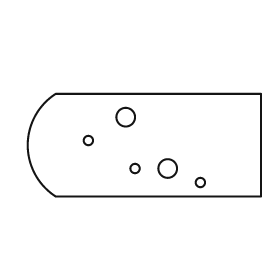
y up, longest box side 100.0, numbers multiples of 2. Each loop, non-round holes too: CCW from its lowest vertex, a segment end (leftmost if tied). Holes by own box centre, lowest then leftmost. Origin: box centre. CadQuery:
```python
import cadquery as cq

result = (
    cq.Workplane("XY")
    .moveTo(-38.0, -22.0)
    .lineTo(50.0, -22.0)
    .lineTo(50.0, 22.0)
    .lineTo(-38.0, 22.0)
    .threePointArc((-50.0, 0.0), (-38.0, -22.0))
    .close()
    .moveTo(24.0, -16.0)
    .circle(2.0)
    .moveTo(-4.0, -10.0)
    .circle(2.0)
    .moveTo(10.0, -10.0)
    .circle(4.0)
    .moveTo(-24.0, 2.0)
    .circle(2.0)
    .moveTo(-8.0, 12.0)
    .circle(4.0)
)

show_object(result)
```